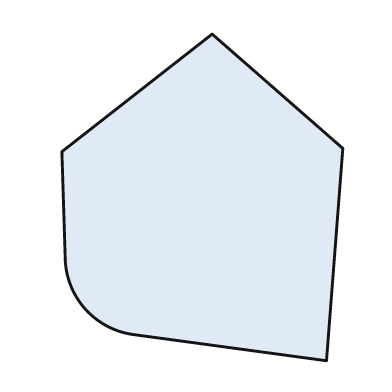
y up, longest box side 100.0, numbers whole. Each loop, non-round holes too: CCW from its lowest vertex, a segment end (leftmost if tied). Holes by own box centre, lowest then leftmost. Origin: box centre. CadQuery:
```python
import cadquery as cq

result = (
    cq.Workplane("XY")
    .moveTo(38.0, -50.0)
    .lineTo(43.0, 15.0)
    .lineTo(3.0, 50.0)
    .lineTo(-43.0, 14.0)
    .lineTo(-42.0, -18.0)
    .threePointArc((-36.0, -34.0), (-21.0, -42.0))
    .close()
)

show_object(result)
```